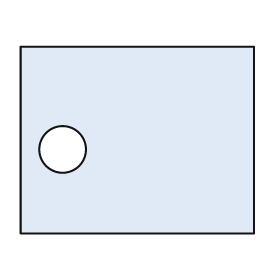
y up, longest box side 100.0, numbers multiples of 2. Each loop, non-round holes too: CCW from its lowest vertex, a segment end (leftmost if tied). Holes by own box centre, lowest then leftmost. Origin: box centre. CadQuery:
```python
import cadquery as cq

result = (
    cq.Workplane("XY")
    .moveTo(-50.0, -40.0)
    .lineTo(50.0, -40.0)
    .lineTo(50.0, 40.0)
    .lineTo(-50.0, 40.0)
    .close()
    .moveTo(-32.0, -4.0)
    .circle(10.0)
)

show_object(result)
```